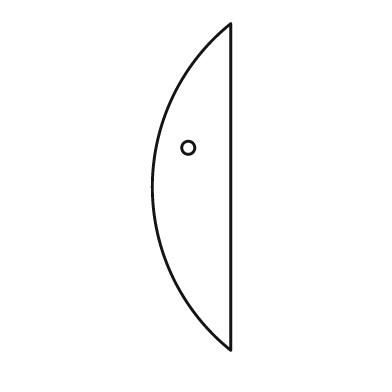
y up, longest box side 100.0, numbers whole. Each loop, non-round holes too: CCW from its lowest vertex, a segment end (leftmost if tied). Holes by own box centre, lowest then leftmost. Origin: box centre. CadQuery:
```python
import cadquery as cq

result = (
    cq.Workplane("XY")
    .moveTo(12.0, -50.0)
    .lineTo(12.0, 50.0)
    .threePointArc((-12.0, 0.0), (12.0, -50.0))
    .close()
    .moveTo(-1.0, 12.0)
    .circle(2.0)
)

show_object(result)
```